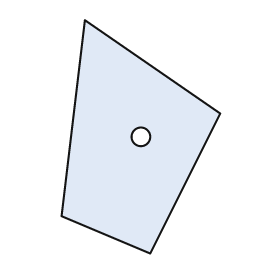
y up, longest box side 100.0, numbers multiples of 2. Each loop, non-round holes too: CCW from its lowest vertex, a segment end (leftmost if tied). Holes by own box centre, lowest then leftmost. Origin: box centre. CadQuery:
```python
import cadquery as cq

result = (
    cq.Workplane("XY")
    .moveTo(4.0, -50.0)
    .lineTo(34.0, 10.0)
    .lineTo(-24.0, 50.0)
    .lineTo(-34.0, -34.0)
    .close()
    .moveTo(0.0, 0.0)
    .circle(4.0)
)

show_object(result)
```